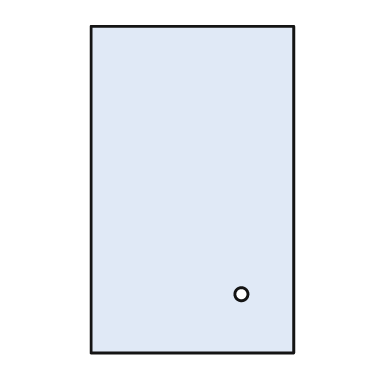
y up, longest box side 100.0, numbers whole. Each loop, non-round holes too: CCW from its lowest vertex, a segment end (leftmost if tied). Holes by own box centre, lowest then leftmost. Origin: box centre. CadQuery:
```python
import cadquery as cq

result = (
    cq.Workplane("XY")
    .moveTo(-31.0, -50.0)
    .lineTo(31.0, -50.0)
    .lineTo(31.0, 50.0)
    .lineTo(-31.0, 50.0)
    .close()
    .moveTo(15.0, -32.0)
    .circle(2.0)
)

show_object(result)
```